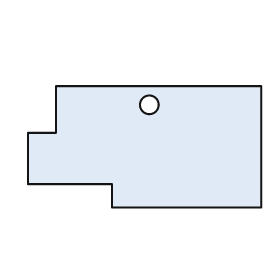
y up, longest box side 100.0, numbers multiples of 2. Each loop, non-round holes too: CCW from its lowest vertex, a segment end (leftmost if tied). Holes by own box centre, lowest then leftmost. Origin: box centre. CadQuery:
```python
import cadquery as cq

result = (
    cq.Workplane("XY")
    .moveTo(-14.0, -26.0)
    .lineTo(50.0, -26.0)
    .lineTo(50.0, 26.0)
    .lineTo(-38.0, 26.0)
    .lineTo(-38.0, 6.0)
    .lineTo(-50.0, 6.0)
    .lineTo(-50.0, -16.0)
    .lineTo(-14.0, -16.0)
    .close()
    .moveTo(2.0, 18.0)
    .circle(4.0)
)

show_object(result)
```